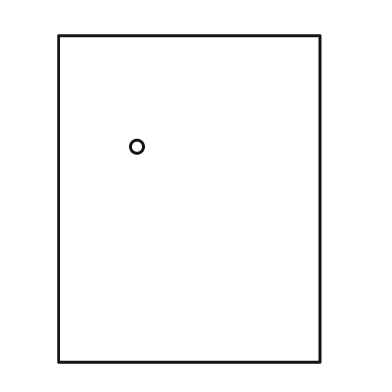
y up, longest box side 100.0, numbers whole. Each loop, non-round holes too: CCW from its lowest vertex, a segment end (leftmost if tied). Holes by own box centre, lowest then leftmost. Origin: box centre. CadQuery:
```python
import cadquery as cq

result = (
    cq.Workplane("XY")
    .moveTo(-40.0, -50.0)
    .lineTo(40.0, -50.0)
    .lineTo(40.0, 50.0)
    .lineTo(-40.0, 50.0)
    .close()
    .moveTo(-16.0, 16.0)
    .circle(2.0)
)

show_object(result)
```